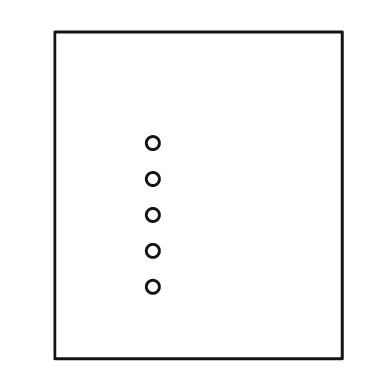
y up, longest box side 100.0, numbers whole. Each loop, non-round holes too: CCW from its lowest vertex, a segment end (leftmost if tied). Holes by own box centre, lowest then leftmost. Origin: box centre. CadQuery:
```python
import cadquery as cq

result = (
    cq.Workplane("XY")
    .moveTo(-44.0, -50.0)
    .lineTo(44.0, -50.0)
    .lineTo(44.0, 50.0)
    .lineTo(-44.0, 50.0)
    .close()
    .moveTo(-14.0, -28.0)
    .circle(2.0)
    .moveTo(-14.0, -17.0)
    .circle(2.0)
    .moveTo(-14.0, -6.0)
    .circle(2.0)
    .moveTo(-14.0, 5.0)
    .circle(2.0)
    .moveTo(-14.0, 16.0)
    .circle(2.0)
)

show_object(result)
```